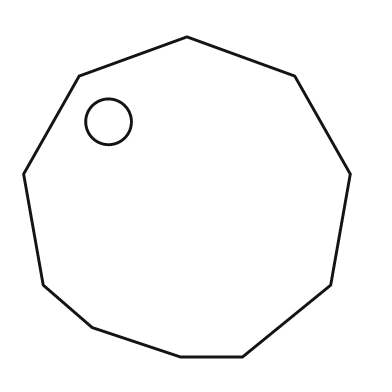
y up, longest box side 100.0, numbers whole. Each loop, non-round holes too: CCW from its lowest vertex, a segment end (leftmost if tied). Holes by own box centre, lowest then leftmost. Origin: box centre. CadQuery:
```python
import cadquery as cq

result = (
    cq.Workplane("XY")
    .moveTo(-2.0, -49.0)
    .lineTo(17.0, -49.0)
    .lineTo(44.0, -27.0)
    .lineTo(50.0, 7.0)
    .lineTo(33.0, 37.0)
    .lineTo(0.0, 49.0)
    .lineTo(-33.0, 37.0)
    .lineTo(-50.0, 7.0)
    .lineTo(-44.0, -27.0)
    .lineTo(-29.0, -40.0)
    .close()
    .moveTo(-24.0, 23.0)
    .circle(7.0)
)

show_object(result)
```